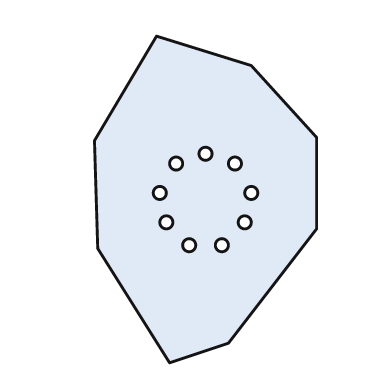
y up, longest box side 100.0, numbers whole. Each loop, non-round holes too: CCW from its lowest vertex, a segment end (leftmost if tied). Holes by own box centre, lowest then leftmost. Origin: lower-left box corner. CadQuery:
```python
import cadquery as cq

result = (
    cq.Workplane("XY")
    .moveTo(23.0, 0.0)
    .lineTo(41.0, 6.0)
    .lineTo(68.0, 41.0)
    .lineTo(68.0, 69.0)
    .lineTo(48.0, 91.0)
    .lineTo(19.0, 100.0)
    .lineTo(0.0, 68.0)
    .lineTo(1.0, 35.0)
    .close()
    .moveTo(29.0, 36.0)
    .circle(2.0)
    .moveTo(39.0, 36.0)
    .circle(2.0)
    .moveTo(22.0, 43.0)
    .circle(2.0)
    .moveTo(46.0, 43.0)
    .circle(2.0)
    .moveTo(20.0, 52.0)
    .circle(2.0)
    .moveTo(48.0, 52.0)
    .circle(2.0)
    .moveTo(25.0, 61.0)
    .circle(2.0)
    .moveTo(43.0, 61.0)
    .circle(2.0)
    .moveTo(34.0, 64.0)
    .circle(2.0)
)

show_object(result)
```